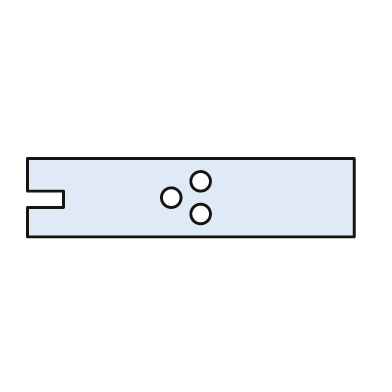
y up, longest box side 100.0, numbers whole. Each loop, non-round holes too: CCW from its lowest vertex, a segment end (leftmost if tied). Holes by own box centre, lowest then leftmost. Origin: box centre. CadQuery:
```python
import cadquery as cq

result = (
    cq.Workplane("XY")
    .moveTo(-50.0, -12.0)
    .lineTo(50.0, -12.0)
    .lineTo(50.0, 12.0)
    .lineTo(-50.0, 12.0)
    .lineTo(-50.0, 2.0)
    .lineTo(-39.0, 2.0)
    .lineTo(-39.0, -3.0)
    .lineTo(-50.0, -3.0)
    .close()
    .moveTo(3.0, -5.0)
    .circle(3.0)
    .moveTo(-6.0, 0.0)
    .circle(3.0)
    .moveTo(3.0, 5.0)
    .circle(3.0)
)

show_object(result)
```